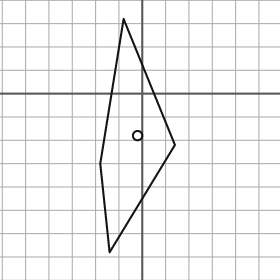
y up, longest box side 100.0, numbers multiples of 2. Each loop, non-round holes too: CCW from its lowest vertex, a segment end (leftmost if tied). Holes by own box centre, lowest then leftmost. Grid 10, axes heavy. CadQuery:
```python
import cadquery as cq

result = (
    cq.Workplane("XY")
    .moveTo(-14.0, -68.0)
    .lineTo(14.0, -22.0)
    .lineTo(-8.0, 32.0)
    .lineTo(-18.0, -30.0)
    .close()
    .moveTo(-2.0, -18.0)
    .circle(2.0)
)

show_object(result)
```